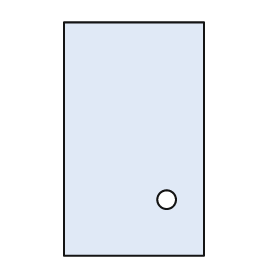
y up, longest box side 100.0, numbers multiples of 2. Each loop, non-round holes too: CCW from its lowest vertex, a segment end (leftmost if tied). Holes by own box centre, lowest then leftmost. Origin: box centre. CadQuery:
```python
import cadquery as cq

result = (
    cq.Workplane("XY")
    .moveTo(-30.0, -50.0)
    .lineTo(30.0, -50.0)
    .lineTo(30.0, 50.0)
    .lineTo(-30.0, 50.0)
    .close()
    .moveTo(14.0, -26.0)
    .circle(4.0)
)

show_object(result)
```